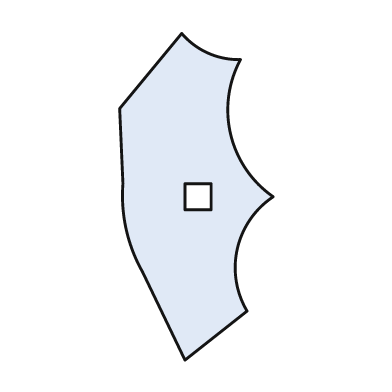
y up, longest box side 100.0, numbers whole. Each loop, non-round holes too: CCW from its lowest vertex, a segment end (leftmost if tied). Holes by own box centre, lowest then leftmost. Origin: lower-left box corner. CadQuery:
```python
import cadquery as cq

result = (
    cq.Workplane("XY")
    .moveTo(20.0, 0.0)
    .lineTo(39.0, 15.0)
    .threePointArc((36.0, 34.0), (47.0, 50.0))
    .threePointArc((34.0, 69.0), (37.0, 92.0))
    .threePointArc((27.0, 94.0), (19.0, 100.0))
    .lineTo(0.0, 77.0)
    .lineTo(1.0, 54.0)
    .threePointArc((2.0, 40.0), (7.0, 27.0))
    .close()
    .moveTo(20.0, 46.0)
    .lineTo(28.0, 46.0)
    .lineTo(28.0, 54.0)
    .lineTo(20.0, 54.0)
    .close()
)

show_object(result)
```